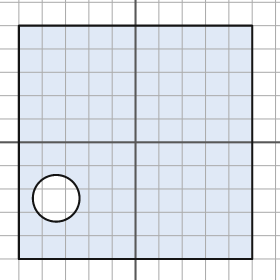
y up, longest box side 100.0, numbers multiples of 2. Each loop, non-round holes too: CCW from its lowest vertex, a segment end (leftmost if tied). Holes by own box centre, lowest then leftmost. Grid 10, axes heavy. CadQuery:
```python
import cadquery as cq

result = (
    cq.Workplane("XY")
    .moveTo(-50.0, -50.0)
    .lineTo(50.0, -50.0)
    .lineTo(50.0, 50.0)
    .lineTo(-50.0, 50.0)
    .close()
    .moveTo(-34.0, -24.0)
    .circle(10.0)
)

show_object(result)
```